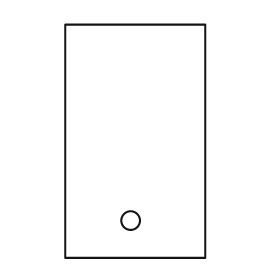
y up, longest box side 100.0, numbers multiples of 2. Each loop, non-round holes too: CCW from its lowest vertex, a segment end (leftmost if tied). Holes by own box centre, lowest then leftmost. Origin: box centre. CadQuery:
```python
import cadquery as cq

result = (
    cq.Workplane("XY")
    .moveTo(-30.0, -50.0)
    .lineTo(30.0, -50.0)
    .lineTo(30.0, 50.0)
    .lineTo(-30.0, 50.0)
    .close()
    .moveTo(-2.0, -34.0)
    .circle(4.0)
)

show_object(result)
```